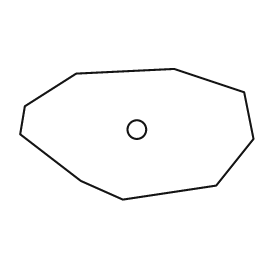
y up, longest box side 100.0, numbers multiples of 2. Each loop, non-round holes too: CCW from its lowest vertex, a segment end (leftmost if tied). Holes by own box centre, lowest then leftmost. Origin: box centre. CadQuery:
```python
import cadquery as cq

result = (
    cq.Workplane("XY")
    .moveTo(-6.0, -28.0)
    .lineTo(34.0, -22.0)
    .lineTo(50.0, -2.0)
    .lineTo(46.0, 18.0)
    .lineTo(16.0, 28.0)
    .lineTo(-26.0, 26.0)
    .lineTo(-48.0, 12.0)
    .lineTo(-50.0, 0.0)
    .lineTo(-24.0, -20.0)
    .close()
    .moveTo(0.0, 2.0)
    .circle(4.0)
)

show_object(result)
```